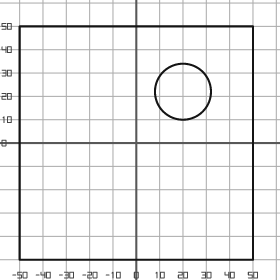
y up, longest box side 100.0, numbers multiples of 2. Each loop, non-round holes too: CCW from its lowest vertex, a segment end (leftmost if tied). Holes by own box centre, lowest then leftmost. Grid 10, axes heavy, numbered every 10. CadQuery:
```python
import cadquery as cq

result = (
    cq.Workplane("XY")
    .moveTo(-50.0, -50.0)
    .lineTo(50.0, -50.0)
    .lineTo(50.0, 50.0)
    .lineTo(-50.0, 50.0)
    .close()
    .moveTo(20.0, 22.0)
    .circle(12.0)
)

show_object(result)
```